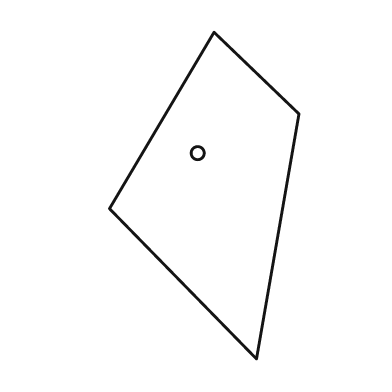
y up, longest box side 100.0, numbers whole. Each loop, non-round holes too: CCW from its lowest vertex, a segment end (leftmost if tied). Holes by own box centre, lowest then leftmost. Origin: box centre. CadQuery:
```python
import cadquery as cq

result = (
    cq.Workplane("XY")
    .moveTo(16.0, -50.0)
    .lineTo(29.0, 25.0)
    .lineTo(3.0, 50.0)
    .lineTo(-29.0, -4.0)
    .close()
    .moveTo(-2.0, 13.0)
    .circle(2.0)
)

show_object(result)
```